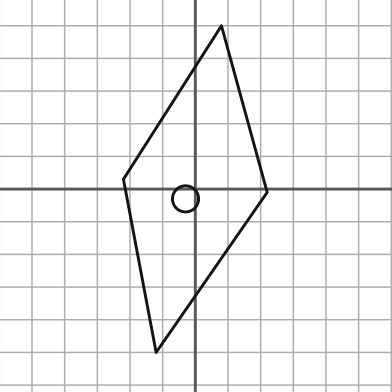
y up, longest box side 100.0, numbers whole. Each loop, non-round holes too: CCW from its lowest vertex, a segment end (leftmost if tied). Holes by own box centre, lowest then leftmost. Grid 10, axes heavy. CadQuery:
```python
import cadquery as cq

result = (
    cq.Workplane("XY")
    .moveTo(-12.0, -50.0)
    .lineTo(22.0, -1.0)
    .lineTo(8.0, 50.0)
    .lineTo(-22.0, 3.0)
    .close()
    .moveTo(-3.0, -3.0)
    .circle(4.0)
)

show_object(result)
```